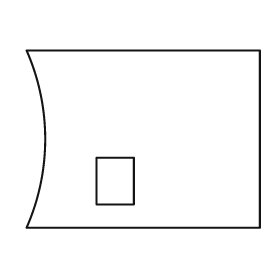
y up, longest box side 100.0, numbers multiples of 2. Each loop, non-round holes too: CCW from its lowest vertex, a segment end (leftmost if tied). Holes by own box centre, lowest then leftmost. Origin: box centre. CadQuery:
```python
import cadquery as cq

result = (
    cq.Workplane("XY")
    .moveTo(-50.0, -38.0)
    .lineTo(50.0, -38.0)
    .lineTo(50.0, 38.0)
    .lineTo(-50.0, 38.0)
    .threePointArc((-42.0, 0.0), (-50.0, -38.0))
    .close()
    .moveTo(-20.0, -28.0)
    .lineTo(-4.0, -28.0)
    .lineTo(-4.0, -8.0)
    .lineTo(-20.0, -8.0)
    .close()
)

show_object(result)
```